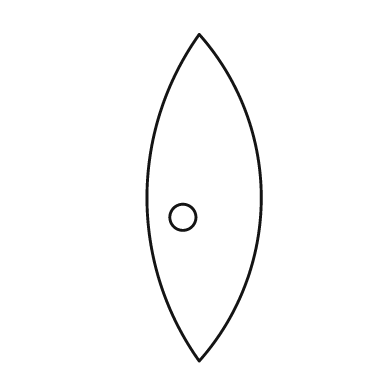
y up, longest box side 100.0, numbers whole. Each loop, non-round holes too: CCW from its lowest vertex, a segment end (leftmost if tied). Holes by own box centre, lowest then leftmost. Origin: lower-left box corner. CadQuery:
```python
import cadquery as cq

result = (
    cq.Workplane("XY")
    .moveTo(16.0, 0.0)
    .threePointArc((35.0, 50.0), (16.0, 100.0))
    .threePointArc((0.0, 50.0), (16.0, 0.0))
    .close()
    .moveTo(11.0, 44.0)
    .circle(4.0)
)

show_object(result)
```